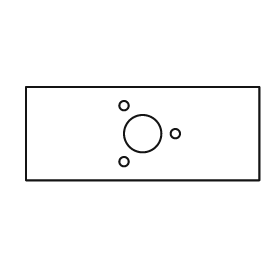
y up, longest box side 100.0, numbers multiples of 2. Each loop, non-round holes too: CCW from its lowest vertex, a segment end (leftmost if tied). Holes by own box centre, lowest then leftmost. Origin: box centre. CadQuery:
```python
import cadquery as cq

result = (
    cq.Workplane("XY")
    .moveTo(-50.0, -20.0)
    .lineTo(50.0, -20.0)
    .lineTo(50.0, 20.0)
    .lineTo(-50.0, 20.0)
    .close()
    .moveTo(-8.0, -12.0)
    .circle(2.0)
    .moveTo(0.0, 0.0)
    .circle(8.0)
    .moveTo(14.0, 0.0)
    .circle(2.0)
    .moveTo(-8.0, 12.0)
    .circle(2.0)
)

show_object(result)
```